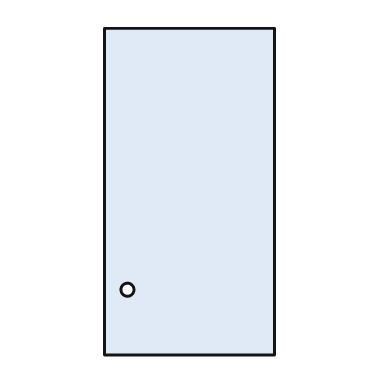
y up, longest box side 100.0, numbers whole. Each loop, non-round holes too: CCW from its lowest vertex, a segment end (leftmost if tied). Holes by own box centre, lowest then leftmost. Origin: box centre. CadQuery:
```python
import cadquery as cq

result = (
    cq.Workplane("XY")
    .moveTo(-26.0, -50.0)
    .lineTo(26.0, -50.0)
    .lineTo(26.0, 50.0)
    .lineTo(-26.0, 50.0)
    .close()
    .moveTo(-19.0, -30.0)
    .circle(2.0)
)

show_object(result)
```